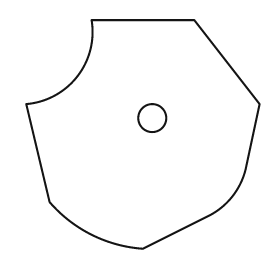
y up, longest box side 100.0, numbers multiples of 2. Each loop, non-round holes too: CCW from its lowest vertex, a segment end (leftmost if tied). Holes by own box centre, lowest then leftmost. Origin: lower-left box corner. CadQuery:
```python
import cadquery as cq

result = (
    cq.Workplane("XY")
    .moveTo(50.0, 0.0)
    .lineTo(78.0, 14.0)
    .threePointArc((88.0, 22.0), (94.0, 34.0))
    .lineTo(100.0, 62.0)
    .lineTo(72.0, 98.0)
    .lineTo(28.0, 98.0)
    .threePointArc((22.0, 74.0), (0.0, 62.0))
    .lineTo(10.0, 20.0)
    .threePointArc((28.0, 6.0), (50.0, 0.0))
    .close()
    .moveTo(54.0, 56.0)
    .circle(6.0)
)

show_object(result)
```